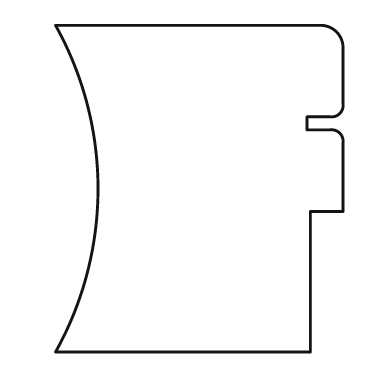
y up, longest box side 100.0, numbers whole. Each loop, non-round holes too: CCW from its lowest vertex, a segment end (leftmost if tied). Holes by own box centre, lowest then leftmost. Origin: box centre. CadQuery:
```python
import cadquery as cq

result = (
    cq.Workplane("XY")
    .moveTo(-44.0, -50.0)
    .lineTo(34.0, -50.0)
    .lineTo(34.0, -7.0)
    .lineTo(44.0, -7.0)
    .lineTo(44.0, 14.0)
    .threePointArc((43.0, 17.0), (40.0, 18.0))
    .lineTo(33.0, 18.0)
    .lineTo(33.0, 22.0)
    .lineTo(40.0, 22.0)
    .threePointArc((43.0, 23.0), (44.0, 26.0))
    .lineTo(44.0, 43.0)
    .threePointArc((42.0, 48.0), (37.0, 50.0))
    .lineTo(-44.0, 50.0)
    .threePointArc((-31.0, 0.0), (-44.0, -50.0))
    .close()
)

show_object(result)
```